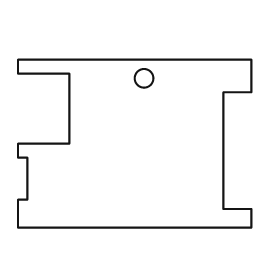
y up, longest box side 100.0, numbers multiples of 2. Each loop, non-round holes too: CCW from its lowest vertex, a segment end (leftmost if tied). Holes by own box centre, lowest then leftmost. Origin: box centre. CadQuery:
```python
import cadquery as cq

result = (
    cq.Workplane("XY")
    .moveTo(-50.0, -36.0)
    .lineTo(50.0, -36.0)
    .lineTo(50.0, -28.0)
    .lineTo(38.0, -28.0)
    .lineTo(38.0, 22.0)
    .lineTo(50.0, 22.0)
    .lineTo(50.0, 36.0)
    .lineTo(-50.0, 36.0)
    .lineTo(-50.0, 30.0)
    .lineTo(-28.0, 30.0)
    .lineTo(-28.0, 0.0)
    .lineTo(-50.0, 0.0)
    .lineTo(-50.0, -6.0)
    .lineTo(-46.0, -6.0)
    .lineTo(-46.0, -24.0)
    .lineTo(-50.0, -24.0)
    .close()
    .moveTo(4.0, 28.0)
    .circle(4.0)
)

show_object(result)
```